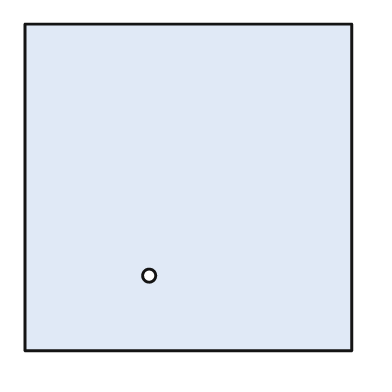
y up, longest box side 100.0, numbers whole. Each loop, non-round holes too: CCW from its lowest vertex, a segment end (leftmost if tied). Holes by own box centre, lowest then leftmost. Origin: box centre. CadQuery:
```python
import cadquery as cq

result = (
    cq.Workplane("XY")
    .moveTo(-50.0, -50.0)
    .lineTo(50.0, -50.0)
    .lineTo(50.0, 50.0)
    .lineTo(-50.0, 50.0)
    .close()
    .moveTo(-12.0, -27.0)
    .circle(2.0)
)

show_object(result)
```